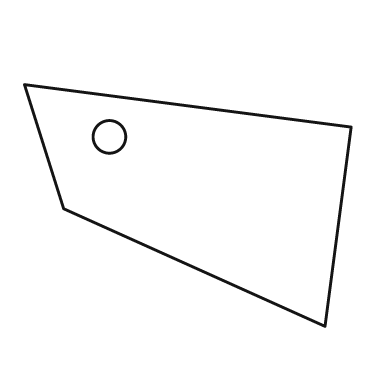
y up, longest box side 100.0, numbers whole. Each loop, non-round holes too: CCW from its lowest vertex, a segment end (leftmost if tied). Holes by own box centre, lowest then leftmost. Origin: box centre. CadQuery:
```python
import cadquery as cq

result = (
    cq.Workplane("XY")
    .moveTo(42.0, -37.0)
    .lineTo(50.0, 24.0)
    .lineTo(-50.0, 37.0)
    .lineTo(-38.0, -1.0)
    .close()
    .moveTo(-24.0, 21.0)
    .circle(5.0)
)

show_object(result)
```